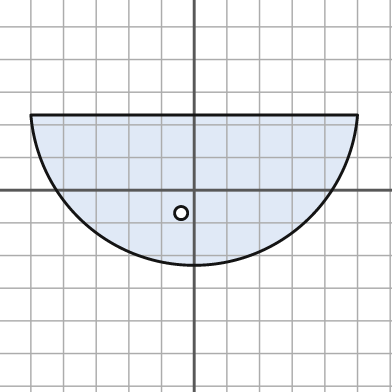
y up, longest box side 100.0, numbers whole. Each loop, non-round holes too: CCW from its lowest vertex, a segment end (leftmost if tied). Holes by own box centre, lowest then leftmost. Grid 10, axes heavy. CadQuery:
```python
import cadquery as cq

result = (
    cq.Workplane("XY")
    .moveTo(-50.0, 23.0)
    .threePointArc((0.0, -23.0), (50.0, 23.0))
    .close()
    .moveTo(-4.0, -7.0)
    .circle(2.0)
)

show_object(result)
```